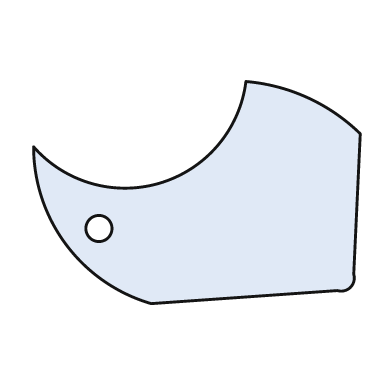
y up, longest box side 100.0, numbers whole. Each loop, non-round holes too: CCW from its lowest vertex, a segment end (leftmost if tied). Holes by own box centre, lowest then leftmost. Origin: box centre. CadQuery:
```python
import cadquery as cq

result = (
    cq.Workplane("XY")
    .moveTo(-14.0, -34.0)
    .lineTo(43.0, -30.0)
    .threePointArc((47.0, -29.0), (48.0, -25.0))
    .lineTo(50.0, 18.0)
    .threePointArc((34.0, 29.0), (15.0, 34.0))
    .threePointArc((-11.0, 3.0), (-50.0, 14.0))
    .threePointArc((-40.0, -16.0), (-14.0, -34.0))
    .close()
    .moveTo(-30.0, -11.0)
    .circle(4.0)
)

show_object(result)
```